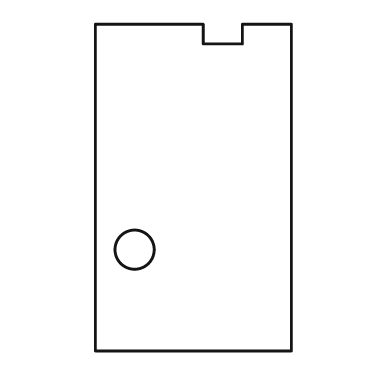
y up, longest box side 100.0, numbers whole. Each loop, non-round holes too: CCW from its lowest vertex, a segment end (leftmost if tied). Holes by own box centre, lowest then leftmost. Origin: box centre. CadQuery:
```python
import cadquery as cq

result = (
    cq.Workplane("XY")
    .moveTo(-30.0, -50.0)
    .lineTo(30.0, -50.0)
    .lineTo(30.0, 50.0)
    .lineTo(15.0, 50.0)
    .lineTo(15.0, 44.0)
    .lineTo(3.0, 44.0)
    .lineTo(3.0, 50.0)
    .lineTo(-30.0, 50.0)
    .close()
    .moveTo(-18.0, -19.0)
    .circle(6.0)
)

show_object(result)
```